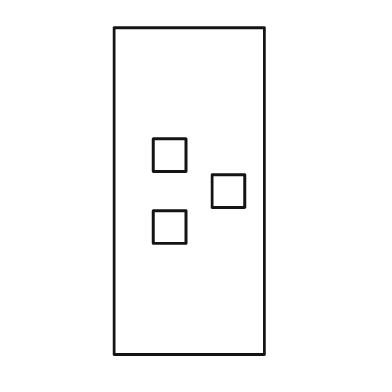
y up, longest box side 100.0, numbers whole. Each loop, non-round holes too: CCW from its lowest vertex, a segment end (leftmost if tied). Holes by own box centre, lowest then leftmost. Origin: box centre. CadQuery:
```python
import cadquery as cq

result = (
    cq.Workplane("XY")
    .moveTo(-23.0, -50.0)
    .lineTo(23.0, -50.0)
    .lineTo(23.0, 50.0)
    .lineTo(-23.0, 50.0)
    .close()
    .moveTo(-11.0, -16.0)
    .lineTo(-1.0, -16.0)
    .lineTo(-1.0, -6.0)
    .lineTo(-11.0, -6.0)
    .close()
    .moveTo(7.0, -5.0)
    .lineTo(17.0, -5.0)
    .lineTo(17.0, 5.0)
    .lineTo(7.0, 5.0)
    .close()
    .moveTo(-11.0, 6.0)
    .lineTo(-1.0, 6.0)
    .lineTo(-1.0, 16.0)
    .lineTo(-11.0, 16.0)
    .close()
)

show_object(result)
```